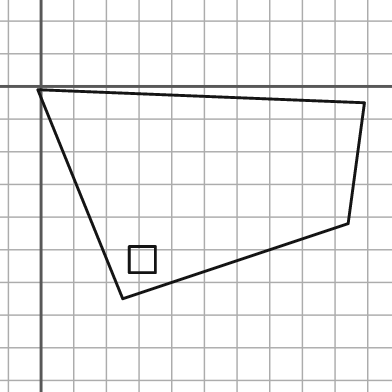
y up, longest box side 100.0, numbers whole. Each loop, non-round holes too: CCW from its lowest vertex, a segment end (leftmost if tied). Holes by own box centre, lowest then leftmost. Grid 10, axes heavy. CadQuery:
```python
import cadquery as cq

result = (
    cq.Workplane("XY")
    .moveTo(25.0, -65.0)
    .lineTo(94.0, -42.0)
    .lineTo(99.0, -5.0)
    .lineTo(-1.0, -1.0)
    .close()
    .moveTo(27.0, -57.0)
    .lineTo(35.0, -57.0)
    .lineTo(35.0, -49.0)
    .lineTo(27.0, -49.0)
    .close()
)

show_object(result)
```